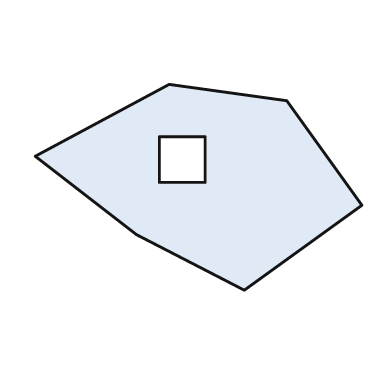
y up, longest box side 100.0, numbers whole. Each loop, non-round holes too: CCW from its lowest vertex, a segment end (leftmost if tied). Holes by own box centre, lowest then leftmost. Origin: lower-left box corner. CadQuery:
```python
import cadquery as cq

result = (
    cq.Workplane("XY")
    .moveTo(64.0, 0.0)
    .lineTo(100.0, 26.0)
    .lineTo(77.0, 58.0)
    .lineTo(41.0, 63.0)
    .lineTo(0.0, 41.0)
    .lineTo(31.0, 17.0)
    .close()
    .moveTo(38.0, 33.0)
    .lineTo(52.0, 33.0)
    .lineTo(52.0, 47.0)
    .lineTo(38.0, 47.0)
    .close()
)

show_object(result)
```